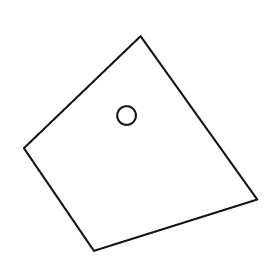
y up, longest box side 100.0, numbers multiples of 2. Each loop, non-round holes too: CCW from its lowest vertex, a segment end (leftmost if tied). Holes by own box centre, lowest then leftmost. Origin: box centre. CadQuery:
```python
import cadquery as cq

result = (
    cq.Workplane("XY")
    .moveTo(-20.0, -46.0)
    .lineTo(50.0, -24.0)
    .lineTo(0.0, 46.0)
    .lineTo(-50.0, -2.0)
    .close()
    .moveTo(-6.0, 12.0)
    .circle(4.0)
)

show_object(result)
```